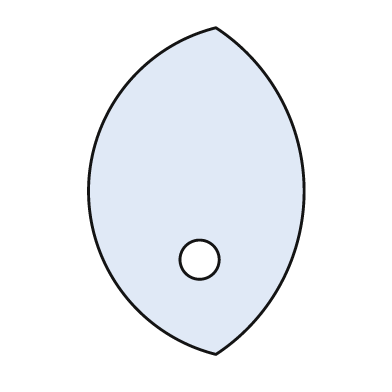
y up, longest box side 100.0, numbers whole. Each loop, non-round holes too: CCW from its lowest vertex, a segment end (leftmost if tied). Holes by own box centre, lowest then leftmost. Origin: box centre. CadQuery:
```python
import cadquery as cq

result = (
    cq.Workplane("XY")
    .moveTo(6.0, -50.0)
    .threePointArc((33.0, 0.0), (6.0, 50.0))
    .threePointArc((-33.0, 0.0), (6.0, -50.0))
    .close()
    .moveTo(1.0, -21.0)
    .circle(6.0)
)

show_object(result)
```